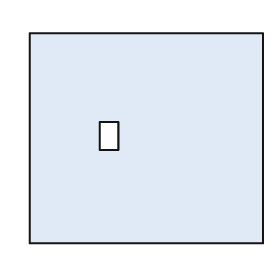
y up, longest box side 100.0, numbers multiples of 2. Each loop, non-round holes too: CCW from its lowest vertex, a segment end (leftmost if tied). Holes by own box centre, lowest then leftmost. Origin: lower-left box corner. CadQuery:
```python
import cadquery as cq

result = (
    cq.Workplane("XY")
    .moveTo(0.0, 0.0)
    .lineTo(100.0, 0.0)
    .lineTo(100.0, 90.0)
    .lineTo(0.0, 90.0)
    .close()
    .moveTo(30.0, 40.0)
    .lineTo(38.0, 40.0)
    .lineTo(38.0, 52.0)
    .lineTo(30.0, 52.0)
    .close()
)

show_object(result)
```